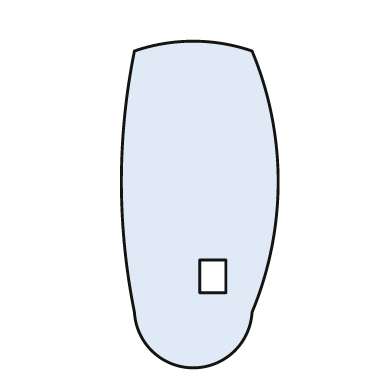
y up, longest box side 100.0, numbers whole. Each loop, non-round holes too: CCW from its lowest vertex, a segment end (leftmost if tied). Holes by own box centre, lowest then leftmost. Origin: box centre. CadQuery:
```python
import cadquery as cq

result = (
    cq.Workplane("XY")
    .moveTo(-20.0, -33.0)
    .threePointArc((-2.0, -50.0), (16.0, -33.0))
    .threePointArc((24.0, 7.0), (16.0, 47.0))
    .threePointArc((-2.0, 50.0), (-20.0, 47.0))
    .threePointArc((-24.0, 7.0), (-20.0, -33.0))
    .close()
    .moveTo(0.0, -27.0)
    .lineTo(8.0, -27.0)
    .lineTo(8.0, -17.0)
    .lineTo(0.0, -17.0)
    .close()
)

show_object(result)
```